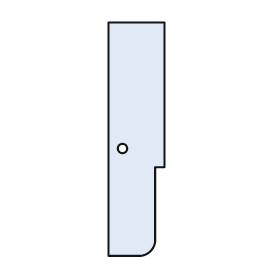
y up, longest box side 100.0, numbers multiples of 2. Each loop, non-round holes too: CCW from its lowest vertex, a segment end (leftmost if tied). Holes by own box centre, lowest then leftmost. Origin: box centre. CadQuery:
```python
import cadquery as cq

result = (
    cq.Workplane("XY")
    .moveTo(-12.0, -50.0)
    .lineTo(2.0, -50.0)
    .threePointArc((6.0, -48.0), (8.0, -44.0))
    .lineTo(8.0, -12.0)
    .lineTo(12.0, -12.0)
    .lineTo(12.0, 50.0)
    .lineTo(-12.0, 50.0)
    .close()
    .moveTo(-6.0, -4.0)
    .circle(2.0)
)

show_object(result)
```